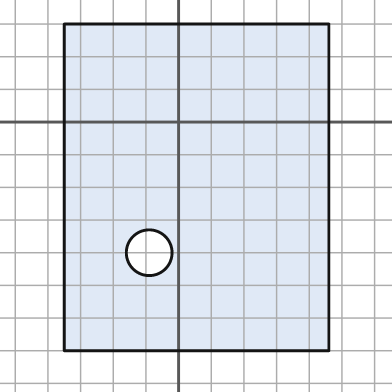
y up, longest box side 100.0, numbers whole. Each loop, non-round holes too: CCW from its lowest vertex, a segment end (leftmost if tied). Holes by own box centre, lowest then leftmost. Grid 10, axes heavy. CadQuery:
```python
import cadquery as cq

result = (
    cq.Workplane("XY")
    .moveTo(-35.0, -70.0)
    .lineTo(46.0, -70.0)
    .lineTo(46.0, 30.0)
    .lineTo(-35.0, 30.0)
    .close()
    .moveTo(-9.0, -40.0)
    .circle(7.0)
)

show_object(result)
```